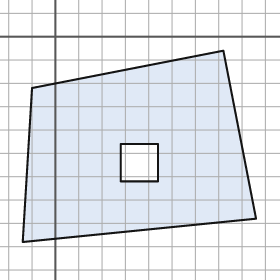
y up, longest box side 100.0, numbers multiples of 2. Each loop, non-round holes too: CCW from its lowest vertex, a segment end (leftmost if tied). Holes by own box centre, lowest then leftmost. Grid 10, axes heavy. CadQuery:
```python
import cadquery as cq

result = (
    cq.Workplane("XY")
    .moveTo(-14.0, -88.0)
    .lineTo(86.0, -78.0)
    .lineTo(72.0, -6.0)
    .lineTo(-10.0, -22.0)
    .close()
    .moveTo(28.0, -62.0)
    .lineTo(44.0, -62.0)
    .lineTo(44.0, -46.0)
    .lineTo(28.0, -46.0)
    .close()
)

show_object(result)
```